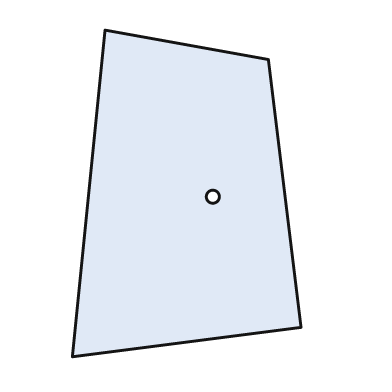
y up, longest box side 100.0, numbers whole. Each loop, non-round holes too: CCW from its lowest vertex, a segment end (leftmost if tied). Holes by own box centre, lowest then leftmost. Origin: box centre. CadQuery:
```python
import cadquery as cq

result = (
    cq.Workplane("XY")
    .moveTo(-35.0, -50.0)
    .lineTo(35.0, -41.0)
    .lineTo(25.0, 41.0)
    .lineTo(-25.0, 50.0)
    .close()
    .moveTo(8.0, -1.0)
    .circle(2.0)
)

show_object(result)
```